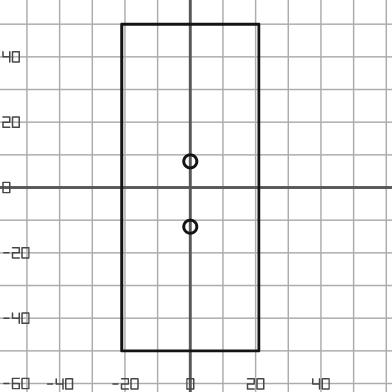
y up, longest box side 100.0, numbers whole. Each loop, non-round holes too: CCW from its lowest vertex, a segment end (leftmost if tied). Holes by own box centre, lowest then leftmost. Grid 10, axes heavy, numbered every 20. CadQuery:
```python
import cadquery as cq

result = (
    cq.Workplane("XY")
    .moveTo(-21.0, -50.0)
    .lineTo(21.0, -50.0)
    .lineTo(21.0, 50.0)
    .lineTo(-21.0, 50.0)
    .close()
    .moveTo(0.0, -12.0)
    .circle(2.0)
    .moveTo(0.0, 8.0)
    .circle(2.0)
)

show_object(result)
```